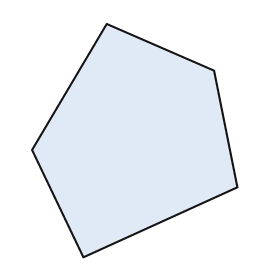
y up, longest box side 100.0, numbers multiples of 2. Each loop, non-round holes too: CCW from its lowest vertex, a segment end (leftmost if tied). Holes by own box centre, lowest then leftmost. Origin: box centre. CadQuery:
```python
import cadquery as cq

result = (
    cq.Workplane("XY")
    .moveTo(-22.0, -50.0)
    .lineTo(44.0, -20.0)
    .lineTo(34.0, 30.0)
    .lineTo(-12.0, 50.0)
    .lineTo(-44.0, -4.0)
    .close()
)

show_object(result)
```